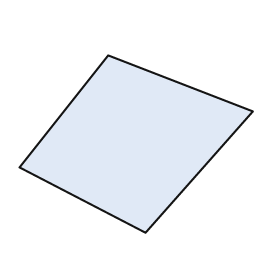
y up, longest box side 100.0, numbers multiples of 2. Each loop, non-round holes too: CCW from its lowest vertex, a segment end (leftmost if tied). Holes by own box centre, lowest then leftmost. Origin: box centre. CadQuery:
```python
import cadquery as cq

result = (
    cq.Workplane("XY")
    .moveTo(4.0, -38.0)
    .lineTo(50.0, 14.0)
    .lineTo(-12.0, 38.0)
    .lineTo(-50.0, -10.0)
    .close()
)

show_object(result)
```